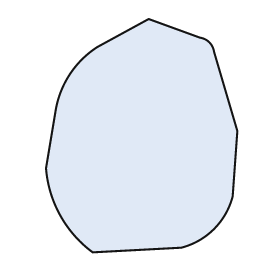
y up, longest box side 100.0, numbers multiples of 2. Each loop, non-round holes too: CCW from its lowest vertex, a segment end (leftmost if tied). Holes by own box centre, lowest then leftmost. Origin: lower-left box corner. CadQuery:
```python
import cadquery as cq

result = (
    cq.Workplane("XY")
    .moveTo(20.0, 0.0)
    .lineTo(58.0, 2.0)
    .threePointArc((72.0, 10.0), (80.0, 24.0))
    .lineTo(82.0, 52.0)
    .lineTo(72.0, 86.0)
    .threePointArc((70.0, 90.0), (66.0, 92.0))
    .lineTo(44.0, 100.0)
    .lineTo(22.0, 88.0)
    .threePointArc((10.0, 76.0), (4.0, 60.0))
    .lineTo(0.0, 36.0)
    .threePointArc((6.0, 16.0), (20.0, 0.0))
    .close()
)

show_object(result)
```